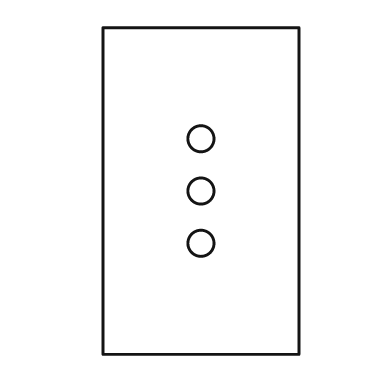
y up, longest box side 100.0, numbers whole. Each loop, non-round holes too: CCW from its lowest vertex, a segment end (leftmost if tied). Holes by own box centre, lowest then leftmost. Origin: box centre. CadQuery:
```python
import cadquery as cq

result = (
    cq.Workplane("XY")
    .moveTo(-30.0, -50.0)
    .lineTo(30.0, -50.0)
    .lineTo(30.0, 50.0)
    .lineTo(-30.0, 50.0)
    .close()
    .moveTo(0.0, -16.0)
    .circle(4.0)
    .moveTo(0.0, 0.0)
    .circle(4.0)
    .moveTo(0.0, 16.0)
    .circle(4.0)
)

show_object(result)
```